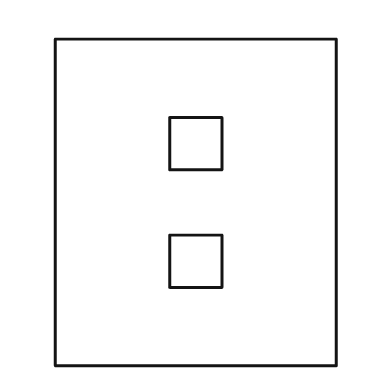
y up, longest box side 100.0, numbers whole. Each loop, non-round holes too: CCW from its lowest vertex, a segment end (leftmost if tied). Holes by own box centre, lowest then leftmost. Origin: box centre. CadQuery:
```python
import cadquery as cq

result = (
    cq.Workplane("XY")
    .moveTo(-43.0, -50.0)
    .lineTo(43.0, -50.0)
    .lineTo(43.0, 50.0)
    .lineTo(-43.0, 50.0)
    .close()
    .moveTo(-8.0, -26.0)
    .lineTo(8.0, -26.0)
    .lineTo(8.0, -10.0)
    .lineTo(-8.0, -10.0)
    .close()
    .moveTo(-8.0, 10.0)
    .lineTo(8.0, 10.0)
    .lineTo(8.0, 26.0)
    .lineTo(-8.0, 26.0)
    .close()
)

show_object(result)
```